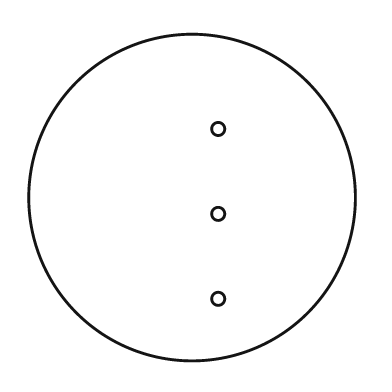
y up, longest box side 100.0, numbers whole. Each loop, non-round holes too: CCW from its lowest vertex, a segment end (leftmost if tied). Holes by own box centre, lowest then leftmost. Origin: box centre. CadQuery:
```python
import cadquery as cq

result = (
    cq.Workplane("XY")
    .moveTo(0.0, 0.0)
    .circle(50.0)
    .moveTo(8.0, -31.0)
    .circle(2.0)
    .moveTo(8.0, -5.0)
    .circle(2.0)
    .moveTo(8.0, 21.0)
    .circle(2.0)
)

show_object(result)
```